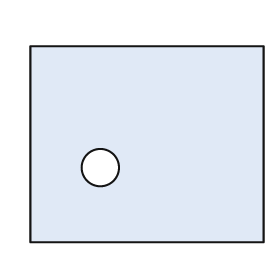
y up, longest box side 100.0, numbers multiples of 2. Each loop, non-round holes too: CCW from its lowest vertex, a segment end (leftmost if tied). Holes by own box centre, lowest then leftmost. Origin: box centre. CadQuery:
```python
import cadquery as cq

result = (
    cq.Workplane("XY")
    .moveTo(-50.0, -42.0)
    .lineTo(50.0, -42.0)
    .lineTo(50.0, 42.0)
    .lineTo(-50.0, 42.0)
    .close()
    .moveTo(-20.0, -10.0)
    .circle(8.0)
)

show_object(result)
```